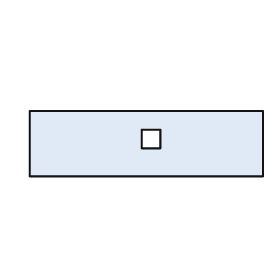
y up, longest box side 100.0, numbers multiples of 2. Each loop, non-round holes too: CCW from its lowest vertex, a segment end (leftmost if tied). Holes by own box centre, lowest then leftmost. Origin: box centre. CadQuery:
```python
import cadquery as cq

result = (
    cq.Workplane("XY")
    .moveTo(-50.0, -14.0)
    .lineTo(50.0, -14.0)
    .lineTo(50.0, 14.0)
    .lineTo(-50.0, 14.0)
    .close()
    .moveTo(-2.0, -2.0)
    .lineTo(6.0, -2.0)
    .lineTo(6.0, 6.0)
    .lineTo(-2.0, 6.0)
    .close()
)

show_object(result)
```